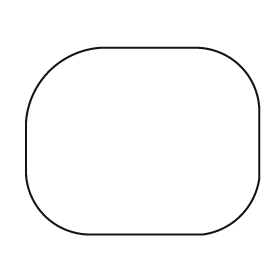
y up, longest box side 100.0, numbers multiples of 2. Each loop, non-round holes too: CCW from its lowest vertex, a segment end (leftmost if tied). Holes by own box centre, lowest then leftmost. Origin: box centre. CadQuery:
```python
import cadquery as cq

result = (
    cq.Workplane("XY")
    .moveTo(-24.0, -40.0)
    .lineTo(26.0, -40.0)
    .threePointArc((42.0, -32.0), (50.0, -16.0))
    .lineTo(50.0, 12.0)
    .threePointArc((42.0, 32.0), (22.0, 40.0))
    .lineTo(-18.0, 40.0)
    .threePointArc((-40.0, 30.0), (-50.0, 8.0))
    .lineTo(-50.0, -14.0)
    .threePointArc((-42.0, -32.0), (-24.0, -40.0))
    .close()
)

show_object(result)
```